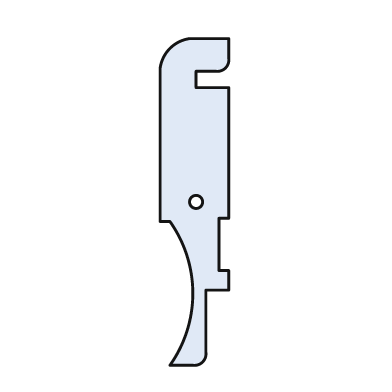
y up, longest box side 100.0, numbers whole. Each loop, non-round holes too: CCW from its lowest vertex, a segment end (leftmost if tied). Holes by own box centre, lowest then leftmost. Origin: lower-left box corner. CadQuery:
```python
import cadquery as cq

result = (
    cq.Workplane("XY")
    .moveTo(3.0, 0.0)
    .lineTo(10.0, 0.0)
    .threePointArc((13.0, 1.0), (14.0, 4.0))
    .lineTo(14.0, 23.0)
    .lineTo(21.0, 23.0)
    .lineTo(21.0, 29.0)
    .lineTo(18.0, 29.0)
    .lineTo(18.0, 45.0)
    .lineTo(21.0, 45.0)
    .lineTo(21.0, 85.0)
    .lineTo(11.0, 85.0)
    .lineTo(11.0, 90.0)
    .lineTo(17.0, 90.0)
    .threePointArc((20.0, 91.0), (21.0, 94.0))
    .lineTo(21.0, 100.0)
    .lineTo(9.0, 100.0)
    .threePointArc((3.0, 97.0), (0.0, 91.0))
    .lineTo(0.0, 44.0)
    .lineTo(3.0, 44.0)
    .threePointArc((10.0, 22.0), (3.0, 0.0))
    .close()
    .moveTo(11.0, 50.0)
    .circle(2.0)
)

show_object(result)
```